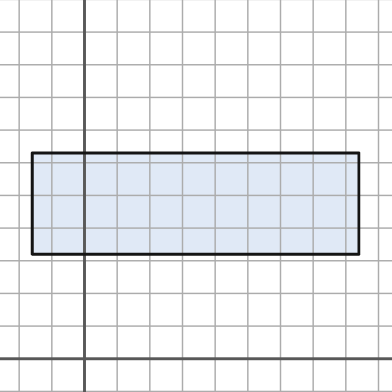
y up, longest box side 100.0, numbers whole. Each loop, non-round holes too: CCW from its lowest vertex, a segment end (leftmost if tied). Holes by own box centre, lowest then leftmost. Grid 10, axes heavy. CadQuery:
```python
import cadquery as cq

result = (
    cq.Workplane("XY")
    .moveTo(-16.0, 32.0)
    .lineTo(84.0, 32.0)
    .lineTo(84.0, 63.0)
    .lineTo(-16.0, 63.0)
    .close()
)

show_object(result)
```